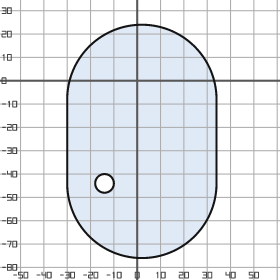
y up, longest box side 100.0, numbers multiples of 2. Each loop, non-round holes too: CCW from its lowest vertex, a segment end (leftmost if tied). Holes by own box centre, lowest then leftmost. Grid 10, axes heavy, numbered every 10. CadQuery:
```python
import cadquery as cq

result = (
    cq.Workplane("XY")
    .moveTo(-30.0, -44.0)
    .threePointArc((2.0, -76.0), (34.0, -44.0))
    .lineTo(34.0, -8.0)
    .threePointArc((2.0, 24.0), (-30.0, -8.0))
    .close()
    .moveTo(-14.0, -44.0)
    .circle(4.0)
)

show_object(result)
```